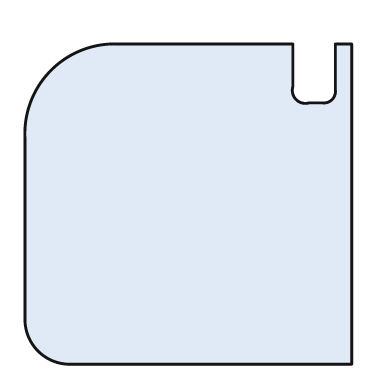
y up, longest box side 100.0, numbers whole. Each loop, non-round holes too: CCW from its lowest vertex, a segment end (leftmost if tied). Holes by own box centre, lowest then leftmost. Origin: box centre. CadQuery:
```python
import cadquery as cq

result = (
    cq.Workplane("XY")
    .moveTo(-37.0, -49.0)
    .lineTo(50.0, -49.0)
    .lineTo(50.0, 49.0)
    .lineTo(45.0, 49.0)
    .lineTo(45.0, 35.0)
    .threePointArc((44.0, 32.0), (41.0, 31.0))
    .lineTo(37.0, 31.0)
    .threePointArc((33.0, 32.0), (32.0, 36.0))
    .lineTo(32.0, 49.0)
    .lineTo(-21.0, 49.0)
    .threePointArc((-42.0, 41.0), (-50.0, 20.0))
    .lineTo(-50.0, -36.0)
    .threePointArc((-46.0, -45.0), (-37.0, -49.0))
    .close()
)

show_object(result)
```